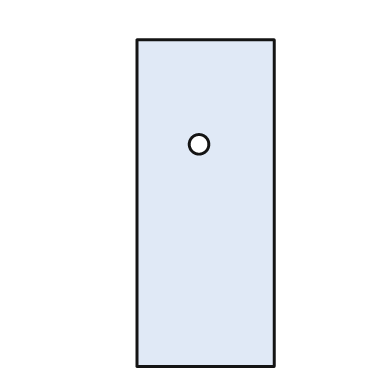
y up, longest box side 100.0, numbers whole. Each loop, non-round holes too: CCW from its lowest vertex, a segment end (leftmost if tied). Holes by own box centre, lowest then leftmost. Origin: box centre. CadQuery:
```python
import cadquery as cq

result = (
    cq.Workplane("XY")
    .moveTo(-21.0, -50.0)
    .lineTo(21.0, -50.0)
    .lineTo(21.0, 50.0)
    .lineTo(-21.0, 50.0)
    .close()
    .moveTo(-2.0, 18.0)
    .circle(3.0)
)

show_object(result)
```